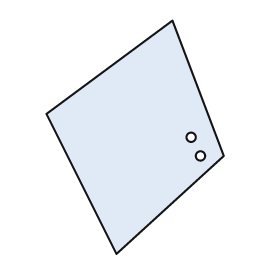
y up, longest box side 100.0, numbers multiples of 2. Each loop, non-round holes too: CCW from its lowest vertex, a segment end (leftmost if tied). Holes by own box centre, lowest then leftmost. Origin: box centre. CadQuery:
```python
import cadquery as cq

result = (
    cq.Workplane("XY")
    .moveTo(-8.0, -50.0)
    .lineTo(38.0, -8.0)
    .lineTo(16.0, 50.0)
    .lineTo(-38.0, 10.0)
    .close()
    .moveTo(28.0, -8.0)
    .circle(2.0)
    .moveTo(24.0, 0.0)
    .circle(2.0)
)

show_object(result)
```